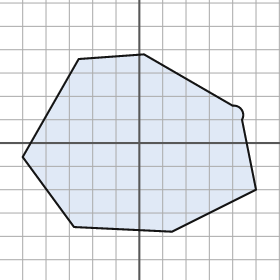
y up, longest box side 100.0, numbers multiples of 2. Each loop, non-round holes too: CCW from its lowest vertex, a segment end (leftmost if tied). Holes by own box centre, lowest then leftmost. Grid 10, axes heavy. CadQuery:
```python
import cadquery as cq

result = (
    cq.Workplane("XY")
    .moveTo(14.0, -38.0)
    .lineTo(50.0, -20.0)
    .lineTo(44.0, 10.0)
    .threePointArc((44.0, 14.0), (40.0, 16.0))
    .lineTo(2.0, 38.0)
    .lineTo(-26.0, 36.0)
    .lineTo(-50.0, -6.0)
    .lineTo(-28.0, -36.0)
    .close()
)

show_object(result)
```